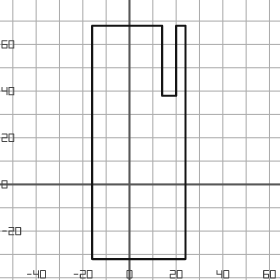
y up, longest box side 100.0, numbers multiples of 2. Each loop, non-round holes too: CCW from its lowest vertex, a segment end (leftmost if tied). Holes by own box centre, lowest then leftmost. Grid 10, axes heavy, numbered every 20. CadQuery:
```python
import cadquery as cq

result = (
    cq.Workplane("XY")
    .moveTo(-16.0, -32.0)
    .lineTo(24.0, -32.0)
    .lineTo(24.0, 68.0)
    .lineTo(20.0, 68.0)
    .lineTo(20.0, 38.0)
    .lineTo(14.0, 38.0)
    .lineTo(14.0, 68.0)
    .lineTo(-16.0, 68.0)
    .close()
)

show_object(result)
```